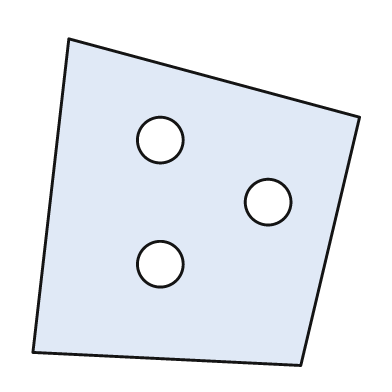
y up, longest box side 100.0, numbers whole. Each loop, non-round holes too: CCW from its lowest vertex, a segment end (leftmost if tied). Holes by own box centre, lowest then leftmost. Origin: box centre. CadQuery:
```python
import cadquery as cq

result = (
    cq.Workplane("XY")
    .moveTo(32.0, -50.0)
    .lineTo(50.0, 26.0)
    .lineTo(-39.0, 50.0)
    .lineTo(-50.0, -46.0)
    .close()
    .moveTo(-11.0, -19.0)
    .circle(7.0)
    .moveTo(22.0, 0.0)
    .circle(7.0)
    .moveTo(-11.0, 19.0)
    .circle(7.0)
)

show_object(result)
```